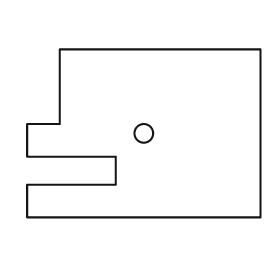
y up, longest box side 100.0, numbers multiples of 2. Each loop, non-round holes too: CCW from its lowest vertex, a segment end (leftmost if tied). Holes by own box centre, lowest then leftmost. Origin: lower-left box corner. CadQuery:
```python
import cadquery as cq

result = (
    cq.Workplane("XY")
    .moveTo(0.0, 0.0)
    .lineTo(100.0, 0.0)
    .lineTo(100.0, 72.0)
    .lineTo(14.0, 72.0)
    .lineTo(14.0, 40.0)
    .lineTo(0.0, 40.0)
    .lineTo(0.0, 26.0)
    .lineTo(38.0, 26.0)
    .lineTo(38.0, 14.0)
    .lineTo(0.0, 14.0)
    .close()
    .moveTo(50.0, 36.0)
    .circle(4.0)
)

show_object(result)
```